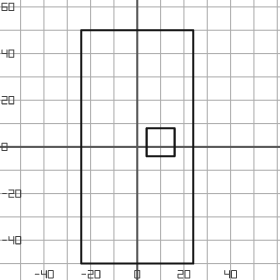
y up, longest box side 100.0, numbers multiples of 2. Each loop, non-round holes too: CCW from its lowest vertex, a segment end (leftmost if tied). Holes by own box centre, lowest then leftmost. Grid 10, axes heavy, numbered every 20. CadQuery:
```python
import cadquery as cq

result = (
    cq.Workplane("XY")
    .moveTo(-24.0, -50.0)
    .lineTo(24.0, -50.0)
    .lineTo(24.0, 50.0)
    .lineTo(-24.0, 50.0)
    .close()
    .moveTo(4.0, -4.0)
    .lineTo(16.0, -4.0)
    .lineTo(16.0, 8.0)
    .lineTo(4.0, 8.0)
    .close()
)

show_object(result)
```